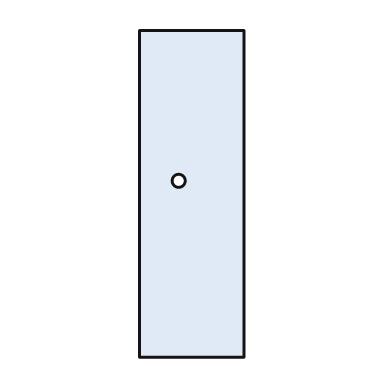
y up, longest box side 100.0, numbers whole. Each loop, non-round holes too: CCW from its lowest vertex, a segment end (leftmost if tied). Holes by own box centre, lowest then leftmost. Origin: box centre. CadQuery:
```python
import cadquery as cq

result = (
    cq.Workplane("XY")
    .moveTo(-16.0, -50.0)
    .lineTo(16.0, -50.0)
    .lineTo(16.0, 50.0)
    .lineTo(-16.0, 50.0)
    .close()
    .moveTo(-4.0, 4.0)
    .circle(2.0)
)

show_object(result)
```